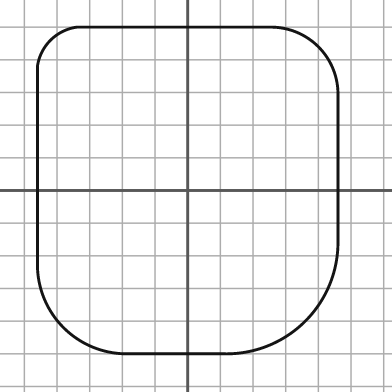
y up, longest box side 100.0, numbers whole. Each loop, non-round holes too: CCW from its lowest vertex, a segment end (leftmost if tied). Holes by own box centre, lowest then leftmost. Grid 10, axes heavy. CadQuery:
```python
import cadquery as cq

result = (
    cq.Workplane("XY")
    .moveTo(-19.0, -50.0)
    .lineTo(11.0, -50.0)
    .threePointArc((36.0, -40.0), (46.0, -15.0))
    .lineTo(46.0, 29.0)
    .threePointArc((40.0, 44.0), (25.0, 50.0))
    .lineTo(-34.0, 50.0)
    .threePointArc((-42.0, 46.0), (-46.0, 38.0))
    .lineTo(-46.0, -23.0)
    .threePointArc((-38.0, -42.0), (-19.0, -50.0))
    .close()
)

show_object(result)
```